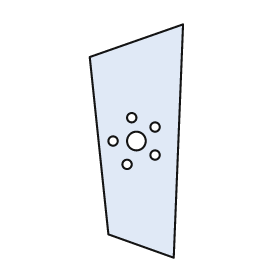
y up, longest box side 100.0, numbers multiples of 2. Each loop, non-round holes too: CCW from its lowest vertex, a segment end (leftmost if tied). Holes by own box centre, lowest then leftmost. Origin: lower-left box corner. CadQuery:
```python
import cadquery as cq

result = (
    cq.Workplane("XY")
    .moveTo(36.0, 0.0)
    .lineTo(40.0, 100.0)
    .lineTo(0.0, 86.0)
    .lineTo(8.0, 10.0)
    .close()
    .moveTo(16.0, 40.0)
    .circle(2.0)
    .moveTo(28.0, 44.0)
    .circle(2.0)
    .moveTo(10.0, 50.0)
    .circle(2.0)
    .moveTo(20.0, 50.0)
    .circle(4.0)
    .moveTo(28.0, 56.0)
    .circle(2.0)
    .moveTo(18.0, 60.0)
    .circle(2.0)
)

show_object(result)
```